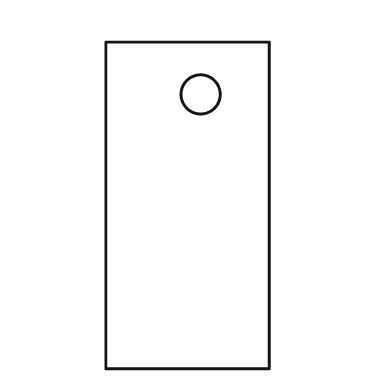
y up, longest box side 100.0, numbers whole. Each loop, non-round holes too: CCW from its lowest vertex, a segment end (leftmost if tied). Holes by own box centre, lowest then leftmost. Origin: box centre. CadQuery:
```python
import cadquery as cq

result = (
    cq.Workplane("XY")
    .moveTo(-25.0, -50.0)
    .lineTo(25.0, -50.0)
    .lineTo(25.0, 50.0)
    .lineTo(-25.0, 50.0)
    .close()
    .moveTo(4.0, 34.0)
    .circle(6.0)
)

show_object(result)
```